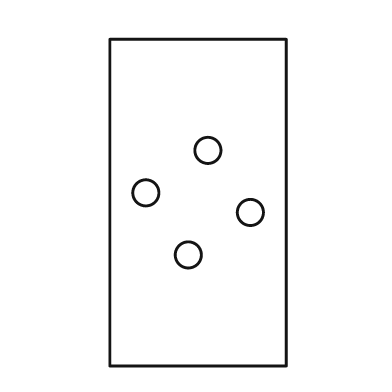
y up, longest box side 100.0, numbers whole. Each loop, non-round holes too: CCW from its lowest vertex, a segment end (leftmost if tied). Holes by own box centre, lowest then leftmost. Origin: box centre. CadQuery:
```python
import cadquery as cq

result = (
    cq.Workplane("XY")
    .moveTo(-27.0, -50.0)
    .lineTo(27.0, -50.0)
    .lineTo(27.0, 50.0)
    .lineTo(-27.0, 50.0)
    .close()
    .moveTo(-3.0, -16.0)
    .circle(4.0)
    .moveTo(16.0, -3.0)
    .circle(4.0)
    .moveTo(-16.0, 3.0)
    .circle(4.0)
    .moveTo(3.0, 16.0)
    .circle(4.0)
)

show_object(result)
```